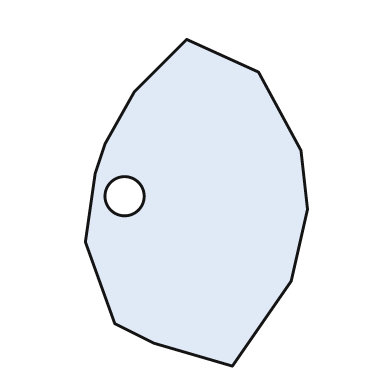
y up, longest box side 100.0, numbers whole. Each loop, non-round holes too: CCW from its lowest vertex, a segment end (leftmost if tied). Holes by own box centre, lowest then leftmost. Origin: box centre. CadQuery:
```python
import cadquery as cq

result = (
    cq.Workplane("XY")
    .moveTo(11.0, -50.0)
    .lineTo(29.0, -24.0)
    .lineTo(34.0, -2.0)
    .lineTo(32.0, 16.0)
    .lineTo(19.0, 40.0)
    .lineTo(-3.0, 50.0)
    .lineTo(-19.0, 34.0)
    .lineTo(-28.0, 18.0)
    .lineTo(-31.0, 9.0)
    .lineTo(-34.0, -12.0)
    .lineTo(-25.0, -37.0)
    .lineTo(-13.0, -43.0)
    .close()
    .moveTo(-22.0, 2.0)
    .circle(6.0)
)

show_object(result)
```